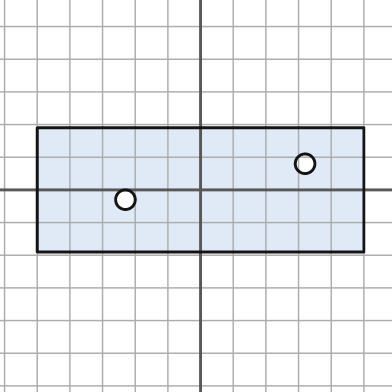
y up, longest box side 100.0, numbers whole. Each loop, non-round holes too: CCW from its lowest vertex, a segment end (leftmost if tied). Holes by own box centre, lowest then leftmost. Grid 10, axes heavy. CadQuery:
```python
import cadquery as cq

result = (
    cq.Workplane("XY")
    .moveTo(-50.0, -19.0)
    .lineTo(50.0, -19.0)
    .lineTo(50.0, 19.0)
    .lineTo(-50.0, 19.0)
    .close()
    .moveTo(-23.0, -3.0)
    .circle(3.0)
    .moveTo(32.0, 8.0)
    .circle(3.0)
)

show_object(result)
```